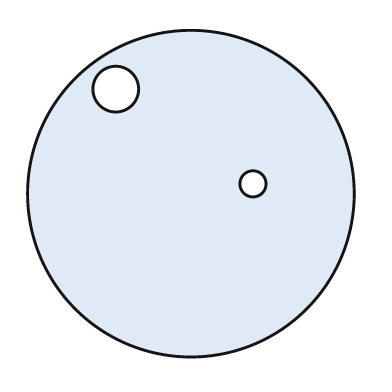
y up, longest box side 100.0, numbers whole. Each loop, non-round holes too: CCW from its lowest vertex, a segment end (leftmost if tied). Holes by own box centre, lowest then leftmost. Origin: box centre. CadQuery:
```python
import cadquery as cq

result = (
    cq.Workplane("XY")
    .moveTo(0.0, 0.0)
    .circle(50.0)
    .moveTo(19.0, 3.0)
    .circle(4.0)
    .moveTo(-23.0, 32.0)
    .circle(7.0)
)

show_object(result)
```